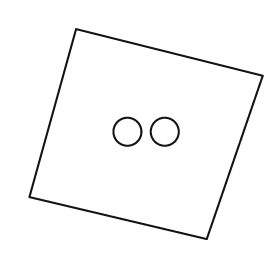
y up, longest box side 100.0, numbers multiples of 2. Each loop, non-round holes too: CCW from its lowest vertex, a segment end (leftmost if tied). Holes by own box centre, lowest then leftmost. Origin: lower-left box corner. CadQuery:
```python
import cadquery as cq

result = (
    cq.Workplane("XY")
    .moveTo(76.0, 0.0)
    .lineTo(100.0, 70.0)
    .lineTo(20.0, 90.0)
    .lineTo(0.0, 18.0)
    .close()
    .moveTo(42.0, 46.0)
    .circle(6.0)
    .moveTo(58.0, 46.0)
    .circle(6.0)
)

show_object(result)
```